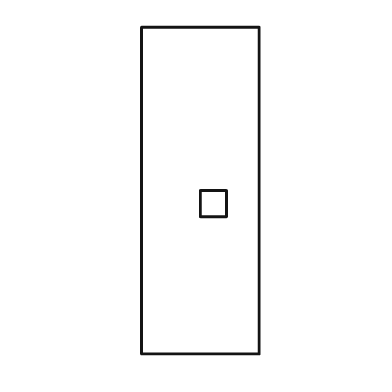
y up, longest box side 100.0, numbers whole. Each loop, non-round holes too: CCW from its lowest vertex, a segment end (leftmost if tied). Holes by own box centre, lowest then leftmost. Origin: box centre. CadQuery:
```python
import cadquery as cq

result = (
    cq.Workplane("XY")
    .moveTo(-18.0, -50.0)
    .lineTo(18.0, -50.0)
    .lineTo(18.0, 50.0)
    .lineTo(-18.0, 50.0)
    .close()
    .moveTo(0.0, -8.0)
    .lineTo(8.0, -8.0)
    .lineTo(8.0, 0.0)
    .lineTo(0.0, 0.0)
    .close()
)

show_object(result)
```